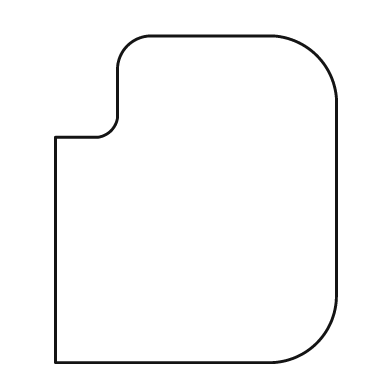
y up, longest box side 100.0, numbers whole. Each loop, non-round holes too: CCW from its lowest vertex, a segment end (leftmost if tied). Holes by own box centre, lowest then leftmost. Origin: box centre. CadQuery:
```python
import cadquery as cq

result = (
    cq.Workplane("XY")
    .moveTo(-43.0, -50.0)
    .lineTo(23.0, -50.0)
    .threePointArc((37.0, -44.0), (43.0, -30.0))
    .lineTo(43.0, 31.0)
    .threePointArc((37.0, 44.0), (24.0, 50.0))
    .lineTo(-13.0, 50.0)
    .threePointArc((-21.0, 47.0), (-24.0, 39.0))
    .lineTo(-24.0, 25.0)
    .threePointArc((-26.0, 21.0), (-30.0, 19.0))
    .lineTo(-43.0, 19.0)
    .close()
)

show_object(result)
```